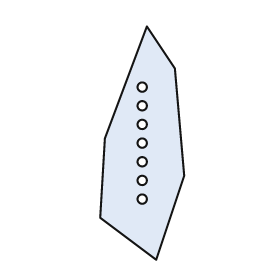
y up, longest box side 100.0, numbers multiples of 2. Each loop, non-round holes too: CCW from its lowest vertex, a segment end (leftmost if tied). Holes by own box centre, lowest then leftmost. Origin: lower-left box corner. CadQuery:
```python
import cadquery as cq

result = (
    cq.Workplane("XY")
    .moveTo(24.0, 0.0)
    .lineTo(36.0, 36.0)
    .lineTo(32.0, 82.0)
    .lineTo(20.0, 100.0)
    .lineTo(2.0, 52.0)
    .lineTo(0.0, 18.0)
    .close()
    .moveTo(18.0, 26.0)
    .circle(2.0)
    .moveTo(18.0, 34.0)
    .circle(2.0)
    .moveTo(18.0, 42.0)
    .circle(2.0)
    .moveTo(18.0, 50.0)
    .circle(2.0)
    .moveTo(18.0, 58.0)
    .circle(2.0)
    .moveTo(18.0, 66.0)
    .circle(2.0)
    .moveTo(18.0, 74.0)
    .circle(2.0)
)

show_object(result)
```